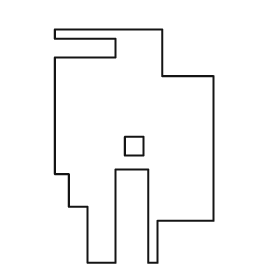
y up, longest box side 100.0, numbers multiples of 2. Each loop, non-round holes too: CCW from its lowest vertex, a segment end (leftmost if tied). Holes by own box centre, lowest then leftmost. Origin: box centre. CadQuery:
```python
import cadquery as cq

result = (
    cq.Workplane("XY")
    .moveTo(-20.0, -50.0)
    .lineTo(-8.0, -50.0)
    .lineTo(-8.0, -10.0)
    .lineTo(6.0, -10.0)
    .lineTo(6.0, -50.0)
    .lineTo(10.0, -50.0)
    .lineTo(10.0, -32.0)
    .lineTo(34.0, -32.0)
    .lineTo(34.0, 30.0)
    .lineTo(12.0, 30.0)
    .lineTo(12.0, 50.0)
    .lineTo(-34.0, 50.0)
    .lineTo(-34.0, 46.0)
    .lineTo(-8.0, 46.0)
    .lineTo(-8.0, 38.0)
    .lineTo(-34.0, 38.0)
    .lineTo(-34.0, -12.0)
    .lineTo(-28.0, -12.0)
    .lineTo(-28.0, -26.0)
    .lineTo(-20.0, -26.0)
    .close()
    .moveTo(-4.0, -4.0)
    .lineTo(4.0, -4.0)
    .lineTo(4.0, 4.0)
    .lineTo(-4.0, 4.0)
    .close()
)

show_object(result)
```